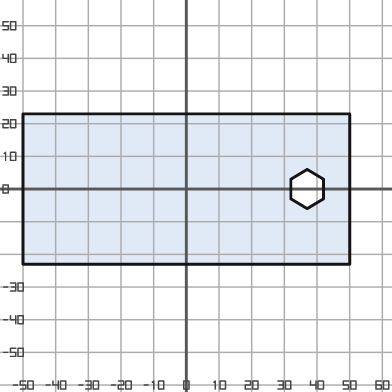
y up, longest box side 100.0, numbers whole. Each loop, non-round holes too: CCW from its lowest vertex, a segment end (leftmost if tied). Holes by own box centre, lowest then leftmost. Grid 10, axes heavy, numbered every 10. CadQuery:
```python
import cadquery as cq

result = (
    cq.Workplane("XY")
    .moveTo(-50.0, -23.0)
    .lineTo(50.0, -23.0)
    .lineTo(50.0, 23.0)
    .lineTo(-50.0, 23.0)
    .close()
    .moveTo(37.0, -6.0)
    .lineTo(42.0, -3.0)
    .lineTo(42.0, 3.0)
    .lineTo(37.0, 6.0)
    .lineTo(32.0, 3.0)
    .lineTo(32.0, -3.0)
    .close()
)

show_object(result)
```